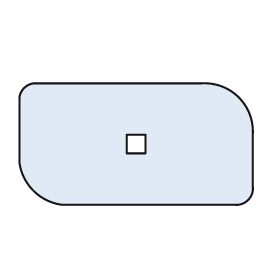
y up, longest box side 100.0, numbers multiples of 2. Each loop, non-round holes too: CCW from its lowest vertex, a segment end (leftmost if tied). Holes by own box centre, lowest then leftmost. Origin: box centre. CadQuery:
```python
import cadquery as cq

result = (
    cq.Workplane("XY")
    .moveTo(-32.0, -26.0)
    .lineTo(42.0, -26.0)
    .threePointArc((48.0, -24.0), (50.0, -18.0))
    .lineTo(50.0, 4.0)
    .threePointArc((44.0, 20.0), (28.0, 26.0))
    .lineTo(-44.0, 26.0)
    .threePointArc((-48.0, 24.0), (-50.0, 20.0))
    .lineTo(-50.0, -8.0)
    .threePointArc((-44.0, -20.0), (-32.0, -26.0))
    .close()
    .moveTo(-4.0, -4.0)
    .lineTo(4.0, -4.0)
    .lineTo(4.0, 4.0)
    .lineTo(-4.0, 4.0)
    .close()
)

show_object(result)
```